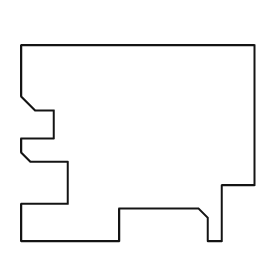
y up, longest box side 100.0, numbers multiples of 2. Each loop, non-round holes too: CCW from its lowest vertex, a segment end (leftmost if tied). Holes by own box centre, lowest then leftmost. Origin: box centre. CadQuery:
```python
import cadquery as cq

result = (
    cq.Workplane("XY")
    .moveTo(-50.0, -42.0)
    .lineTo(-8.0, -42.0)
    .lineTo(-8.0, -28.0)
    .lineTo(26.0, -28.0)
    .lineTo(30.0, -32.0)
    .lineTo(30.0, -42.0)
    .lineTo(36.0, -42.0)
    .lineTo(36.0, -18.0)
    .lineTo(50.0, -18.0)
    .lineTo(50.0, 42.0)
    .lineTo(-50.0, 42.0)
    .lineTo(-50.0, 20.0)
    .lineTo(-44.0, 14.0)
    .lineTo(-36.0, 14.0)
    .lineTo(-36.0, 2.0)
    .lineTo(-50.0, 2.0)
    .lineTo(-50.0, -4.0)
    .lineTo(-46.0, -8.0)
    .lineTo(-30.0, -8.0)
    .lineTo(-30.0, -26.0)
    .lineTo(-50.0, -26.0)
    .close()
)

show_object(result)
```